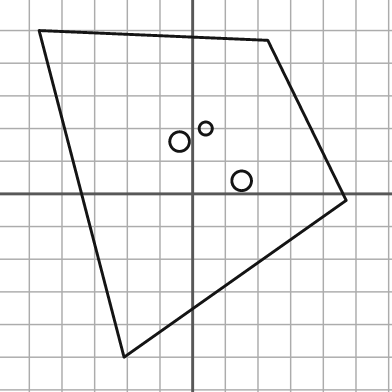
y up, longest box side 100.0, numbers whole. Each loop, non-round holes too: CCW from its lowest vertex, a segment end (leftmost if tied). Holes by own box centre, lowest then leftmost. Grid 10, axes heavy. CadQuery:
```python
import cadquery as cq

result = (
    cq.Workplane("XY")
    .moveTo(-21.0, -50.0)
    .lineTo(47.0, -2.0)
    .lineTo(23.0, 47.0)
    .lineTo(-47.0, 50.0)
    .close()
    .moveTo(15.0, 4.0)
    .circle(3.0)
    .moveTo(-4.0, 16.0)
    .circle(3.0)
    .moveTo(4.0, 20.0)
    .circle(2.0)
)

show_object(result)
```